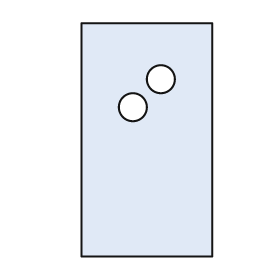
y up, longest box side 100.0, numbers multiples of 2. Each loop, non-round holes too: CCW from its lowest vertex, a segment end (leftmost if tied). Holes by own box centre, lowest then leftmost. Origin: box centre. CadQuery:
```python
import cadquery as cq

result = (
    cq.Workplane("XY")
    .moveTo(-28.0, -50.0)
    .lineTo(28.0, -50.0)
    .lineTo(28.0, 50.0)
    .lineTo(-28.0, 50.0)
    .close()
    .moveTo(-6.0, 14.0)
    .circle(6.0)
    .moveTo(6.0, 26.0)
    .circle(6.0)
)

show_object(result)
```